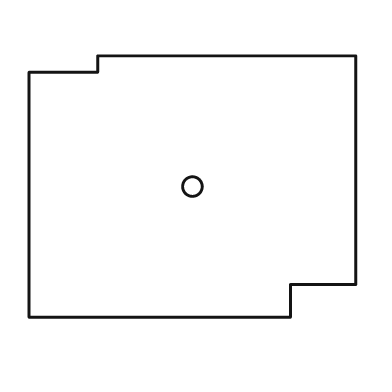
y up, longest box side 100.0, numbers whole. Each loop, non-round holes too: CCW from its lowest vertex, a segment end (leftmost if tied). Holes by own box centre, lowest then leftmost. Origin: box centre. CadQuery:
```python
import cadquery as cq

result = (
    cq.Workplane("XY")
    .moveTo(-50.0, -40.0)
    .lineTo(30.0, -40.0)
    .lineTo(30.0, -30.0)
    .lineTo(50.0, -30.0)
    .lineTo(50.0, 40.0)
    .lineTo(-29.0, 40.0)
    .lineTo(-29.0, 35.0)
    .lineTo(-50.0, 35.0)
    .close()
    .moveTo(0.0, 0.0)
    .circle(3.0)
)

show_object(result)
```